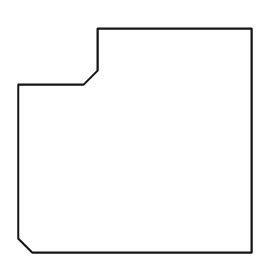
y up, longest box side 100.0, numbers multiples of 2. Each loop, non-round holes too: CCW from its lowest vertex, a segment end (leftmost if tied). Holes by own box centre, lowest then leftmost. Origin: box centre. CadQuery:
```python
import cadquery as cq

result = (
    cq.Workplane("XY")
    .moveTo(-44.0, -48.0)
    .lineTo(50.0, -48.0)
    .lineTo(50.0, 48.0)
    .lineTo(-16.0, 48.0)
    .lineTo(-16.0, 30.0)
    .lineTo(-22.0, 24.0)
    .lineTo(-50.0, 24.0)
    .lineTo(-50.0, -42.0)
    .close()
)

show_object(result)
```